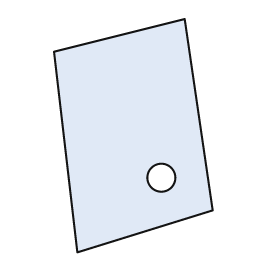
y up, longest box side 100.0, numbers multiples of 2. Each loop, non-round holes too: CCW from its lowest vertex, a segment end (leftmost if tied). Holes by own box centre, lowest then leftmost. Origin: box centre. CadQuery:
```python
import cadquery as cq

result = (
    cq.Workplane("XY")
    .moveTo(-24.0, -50.0)
    .lineTo(34.0, -32.0)
    .lineTo(22.0, 50.0)
    .lineTo(-34.0, 36.0)
    .close()
    .moveTo(12.0, -18.0)
    .circle(6.0)
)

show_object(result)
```